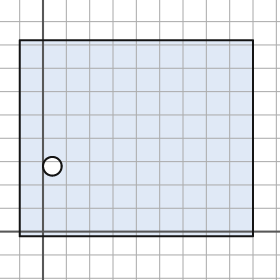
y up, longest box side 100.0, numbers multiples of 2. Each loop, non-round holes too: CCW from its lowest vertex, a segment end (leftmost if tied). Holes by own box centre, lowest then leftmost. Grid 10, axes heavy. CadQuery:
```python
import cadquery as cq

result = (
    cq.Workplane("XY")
    .moveTo(-10.0, -2.0)
    .lineTo(90.0, -2.0)
    .lineTo(90.0, 82.0)
    .lineTo(-10.0, 82.0)
    .close()
    .moveTo(4.0, 28.0)
    .circle(4.0)
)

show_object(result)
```